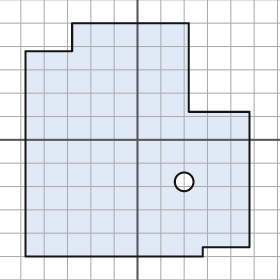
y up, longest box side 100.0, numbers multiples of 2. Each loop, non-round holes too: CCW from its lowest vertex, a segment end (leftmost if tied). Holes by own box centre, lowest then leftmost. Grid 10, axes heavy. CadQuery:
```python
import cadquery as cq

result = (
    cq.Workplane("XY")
    .moveTo(-48.0, -50.0)
    .lineTo(28.0, -50.0)
    .lineTo(28.0, -46.0)
    .lineTo(48.0, -46.0)
    .lineTo(48.0, 12.0)
    .lineTo(22.0, 12.0)
    .lineTo(22.0, 50.0)
    .lineTo(-28.0, 50.0)
    .lineTo(-28.0, 38.0)
    .lineTo(-48.0, 38.0)
    .close()
    .moveTo(20.0, -18.0)
    .circle(4.0)
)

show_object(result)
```